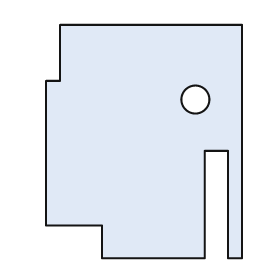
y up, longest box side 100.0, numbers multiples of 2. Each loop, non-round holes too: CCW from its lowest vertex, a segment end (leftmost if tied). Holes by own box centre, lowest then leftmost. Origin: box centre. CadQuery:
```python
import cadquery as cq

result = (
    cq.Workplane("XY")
    .moveTo(-18.0, -50.0)
    .lineTo(26.0, -50.0)
    .lineTo(26.0, -4.0)
    .lineTo(36.0, -4.0)
    .lineTo(36.0, -50.0)
    .lineTo(42.0, -50.0)
    .lineTo(42.0, 50.0)
    .lineTo(-36.0, 50.0)
    .lineTo(-36.0, 26.0)
    .lineTo(-42.0, 26.0)
    .lineTo(-42.0, -36.0)
    .lineTo(-18.0, -36.0)
    .close()
    .moveTo(22.0, 18.0)
    .circle(6.0)
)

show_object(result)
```